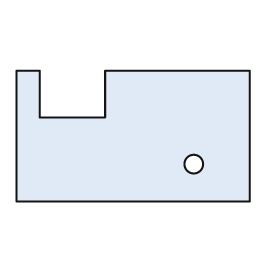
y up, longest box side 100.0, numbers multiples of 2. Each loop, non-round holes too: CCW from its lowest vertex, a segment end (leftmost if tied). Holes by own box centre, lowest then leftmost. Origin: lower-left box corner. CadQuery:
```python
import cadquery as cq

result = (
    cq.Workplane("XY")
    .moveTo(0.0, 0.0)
    .lineTo(100.0, 0.0)
    .lineTo(100.0, 56.0)
    .lineTo(38.0, 56.0)
    .lineTo(38.0, 36.0)
    .lineTo(10.0, 36.0)
    .lineTo(10.0, 56.0)
    .lineTo(0.0, 56.0)
    .close()
    .moveTo(76.0, 16.0)
    .circle(4.0)
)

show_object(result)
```